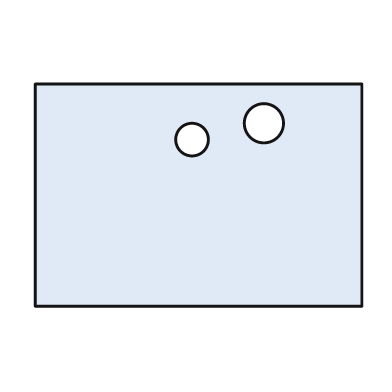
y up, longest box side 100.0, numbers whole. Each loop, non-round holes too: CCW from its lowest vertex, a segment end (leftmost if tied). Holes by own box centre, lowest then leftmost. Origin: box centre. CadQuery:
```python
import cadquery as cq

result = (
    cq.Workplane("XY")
    .moveTo(-50.0, -34.0)
    .lineTo(50.0, -34.0)
    .lineTo(50.0, 34.0)
    .lineTo(-50.0, 34.0)
    .close()
    .moveTo(-2.0, 17.0)
    .circle(5.0)
    .moveTo(20.0, 22.0)
    .circle(6.0)
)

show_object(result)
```